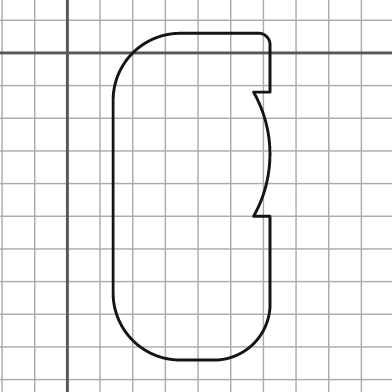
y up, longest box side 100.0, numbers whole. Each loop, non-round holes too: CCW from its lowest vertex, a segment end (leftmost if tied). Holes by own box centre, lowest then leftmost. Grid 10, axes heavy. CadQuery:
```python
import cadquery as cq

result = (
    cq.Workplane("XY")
    .moveTo(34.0, -94.0)
    .lineTo(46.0, -94.0)
    .threePointArc((57.0, -89.0), (62.0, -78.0))
    .lineTo(62.0, -50.0)
    .lineTo(57.0, -50.0)
    .threePointArc((62.0, -31.0), (57.0, -12.0))
    .lineTo(62.0, -12.0)
    .lineTo(62.0, 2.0)
    .threePointArc((61.0, 5.0), (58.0, 6.0))
    .lineTo(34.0, 6.0)
    .threePointArc((20.0, 0.0), (14.0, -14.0))
    .lineTo(14.0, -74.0)
    .threePointArc((20.0, -88.0), (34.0, -94.0))
    .close()
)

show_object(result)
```